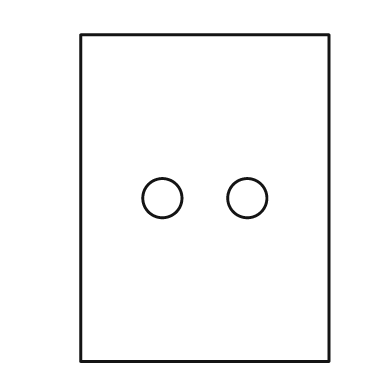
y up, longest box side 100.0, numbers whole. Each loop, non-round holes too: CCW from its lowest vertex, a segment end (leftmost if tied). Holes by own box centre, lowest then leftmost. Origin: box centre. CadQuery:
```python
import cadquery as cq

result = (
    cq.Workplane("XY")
    .moveTo(-38.0, -50.0)
    .lineTo(38.0, -50.0)
    .lineTo(38.0, 50.0)
    .lineTo(-38.0, 50.0)
    .close()
    .moveTo(-13.0, 0.0)
    .circle(6.0)
    .moveTo(13.0, 0.0)
    .circle(6.0)
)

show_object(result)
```